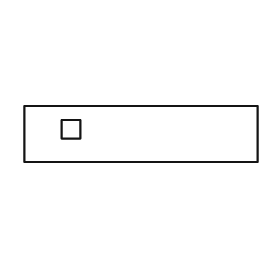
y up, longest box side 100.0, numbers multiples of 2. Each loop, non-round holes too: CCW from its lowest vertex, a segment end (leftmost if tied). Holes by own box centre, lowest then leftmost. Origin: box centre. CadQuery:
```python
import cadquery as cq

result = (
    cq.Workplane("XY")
    .moveTo(-50.0, -12.0)
    .lineTo(50.0, -12.0)
    .lineTo(50.0, 12.0)
    .lineTo(-50.0, 12.0)
    .close()
    .moveTo(-34.0, -2.0)
    .lineTo(-26.0, -2.0)
    .lineTo(-26.0, 6.0)
    .lineTo(-34.0, 6.0)
    .close()
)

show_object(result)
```